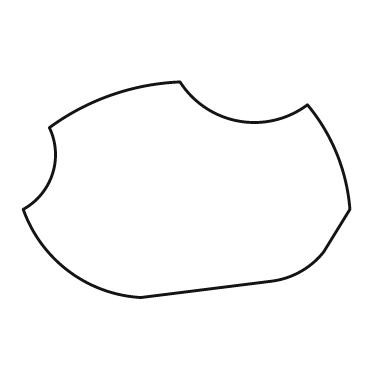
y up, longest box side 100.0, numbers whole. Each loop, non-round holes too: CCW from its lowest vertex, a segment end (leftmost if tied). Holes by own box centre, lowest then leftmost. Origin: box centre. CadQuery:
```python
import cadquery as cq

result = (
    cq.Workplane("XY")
    .moveTo(-14.0, -33.0)
    .lineTo(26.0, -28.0)
    .threePointArc((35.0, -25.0), (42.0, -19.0))
    .lineTo(50.0, -6.0)
    .threePointArc((46.0, 11.0), (37.0, 26.0))
    .threePointArc((16.0, 21.0), (-2.0, 33.0))
    .threePointArc((-23.0, 29.0), (-42.0, 19.0))
    .threePointArc((-41.0, 5.0), (-50.0, -6.0))
    .threePointArc((-36.0, -25.0), (-14.0, -33.0))
    .close()
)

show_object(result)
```